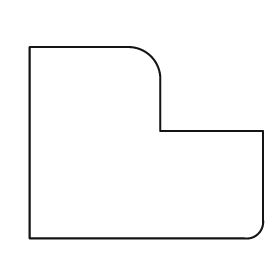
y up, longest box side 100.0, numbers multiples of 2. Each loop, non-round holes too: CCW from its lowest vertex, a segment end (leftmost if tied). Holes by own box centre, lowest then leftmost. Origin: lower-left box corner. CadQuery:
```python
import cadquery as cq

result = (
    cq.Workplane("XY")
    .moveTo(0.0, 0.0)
    .lineTo(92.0, 0.0)
    .threePointArc((98.0, 2.0), (100.0, 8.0))
    .lineTo(100.0, 46.0)
    .lineTo(56.0, 46.0)
    .lineTo(56.0, 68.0)
    .threePointArc((52.0, 78.0), (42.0, 82.0))
    .lineTo(0.0, 82.0)
    .close()
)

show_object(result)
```